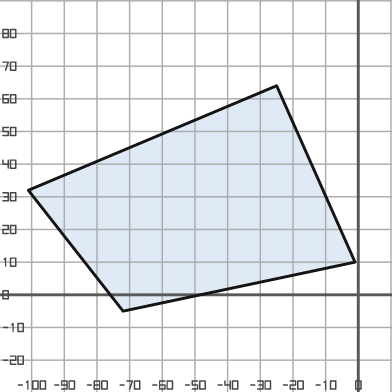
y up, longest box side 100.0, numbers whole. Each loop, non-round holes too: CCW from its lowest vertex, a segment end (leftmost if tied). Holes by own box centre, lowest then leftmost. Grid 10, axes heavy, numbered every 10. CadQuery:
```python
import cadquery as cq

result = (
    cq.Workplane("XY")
    .moveTo(-72.0, -5.0)
    .lineTo(-1.0, 10.0)
    .lineTo(-25.0, 64.0)
    .lineTo(-101.0, 32.0)
    .close()
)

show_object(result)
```